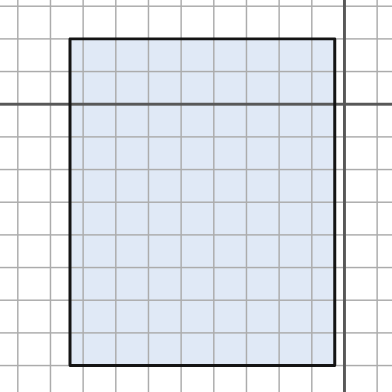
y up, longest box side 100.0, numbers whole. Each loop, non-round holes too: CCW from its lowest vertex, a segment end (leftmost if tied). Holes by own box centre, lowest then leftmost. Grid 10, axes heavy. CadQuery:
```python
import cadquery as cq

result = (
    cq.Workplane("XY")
    .moveTo(-84.0, -80.0)
    .lineTo(-3.0, -80.0)
    .lineTo(-3.0, 20.0)
    .lineTo(-84.0, 20.0)
    .close()
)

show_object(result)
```